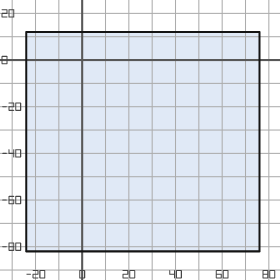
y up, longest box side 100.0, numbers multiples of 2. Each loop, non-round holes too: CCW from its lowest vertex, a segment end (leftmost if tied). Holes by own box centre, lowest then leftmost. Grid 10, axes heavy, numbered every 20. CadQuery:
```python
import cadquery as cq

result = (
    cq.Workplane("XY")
    .moveTo(-24.0, -82.0)
    .lineTo(76.0, -82.0)
    .lineTo(76.0, 12.0)
    .lineTo(-24.0, 12.0)
    .close()
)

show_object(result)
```